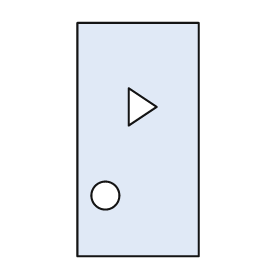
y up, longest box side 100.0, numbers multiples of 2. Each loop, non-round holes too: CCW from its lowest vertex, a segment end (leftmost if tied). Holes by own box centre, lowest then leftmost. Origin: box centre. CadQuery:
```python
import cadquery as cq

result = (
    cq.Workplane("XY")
    .moveTo(-26.0, -50.0)
    .lineTo(26.0, -50.0)
    .lineTo(26.0, 50.0)
    .lineTo(-26.0, 50.0)
    .close()
    .moveTo(-14.0, -24.0)
    .circle(6.0)
    .moveTo(-4.0, 6.0)
    .lineTo(8.0, 14.0)
    .lineTo(-4.0, 22.0)
    .close()
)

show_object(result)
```